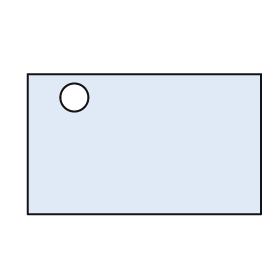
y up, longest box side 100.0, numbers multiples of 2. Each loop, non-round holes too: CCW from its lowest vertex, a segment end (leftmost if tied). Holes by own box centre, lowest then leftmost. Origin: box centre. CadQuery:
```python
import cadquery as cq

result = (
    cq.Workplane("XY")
    .moveTo(-50.0, -30.0)
    .lineTo(50.0, -30.0)
    .lineTo(50.0, 30.0)
    .lineTo(-50.0, 30.0)
    .close()
    .moveTo(-30.0, 20.0)
    .circle(6.0)
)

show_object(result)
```